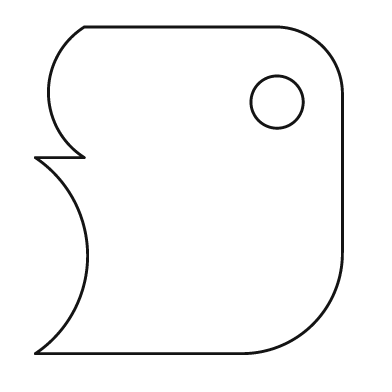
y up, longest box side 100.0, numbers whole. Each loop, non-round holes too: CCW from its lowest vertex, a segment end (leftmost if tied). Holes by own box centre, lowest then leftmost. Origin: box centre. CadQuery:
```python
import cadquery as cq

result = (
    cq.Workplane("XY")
    .moveTo(-47.0, -50.0)
    .lineTo(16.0, -50.0)
    .threePointArc((38.0, -41.0), (47.0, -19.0))
    .lineTo(47.0, 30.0)
    .threePointArc((41.0, 44.0), (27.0, 50.0))
    .lineTo(-32.0, 50.0)
    .threePointArc((-43.0, 30.0), (-32.0, 10.0))
    .lineTo(-47.0, 10.0)
    .threePointArc((-31.0, -20.0), (-47.0, -50.0))
    .close()
    .moveTo(27.0, 27.0)
    .circle(8.0)
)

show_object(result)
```